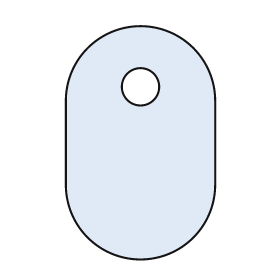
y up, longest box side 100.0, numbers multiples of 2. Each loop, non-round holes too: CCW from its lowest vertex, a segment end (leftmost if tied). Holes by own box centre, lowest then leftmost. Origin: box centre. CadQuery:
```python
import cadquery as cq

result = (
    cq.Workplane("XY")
    .moveTo(-32.0, -18.0)
    .threePointArc((0.0, -50.0), (32.0, -18.0))
    .lineTo(32.0, 18.0)
    .threePointArc((0.0, 50.0), (-32.0, 18.0))
    .close()
    .moveTo(0.0, 24.0)
    .circle(8.0)
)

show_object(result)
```